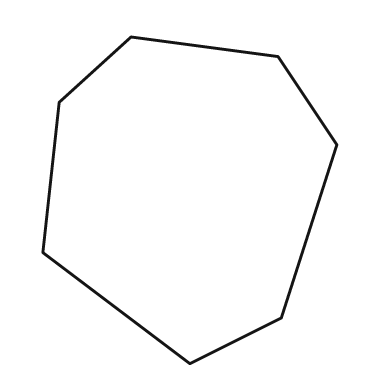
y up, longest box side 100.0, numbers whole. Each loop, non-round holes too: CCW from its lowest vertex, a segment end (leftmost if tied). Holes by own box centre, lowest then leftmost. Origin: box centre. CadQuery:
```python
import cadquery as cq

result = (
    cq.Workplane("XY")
    .moveTo(0.0, -50.0)
    .lineTo(28.0, -36.0)
    .lineTo(45.0, 17.0)
    .lineTo(27.0, 44.0)
    .lineTo(-18.0, 50.0)
    .lineTo(-40.0, 30.0)
    .lineTo(-45.0, -16.0)
    .close()
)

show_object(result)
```